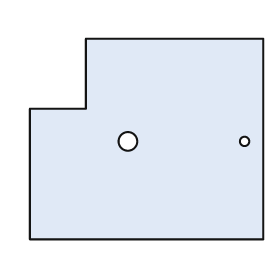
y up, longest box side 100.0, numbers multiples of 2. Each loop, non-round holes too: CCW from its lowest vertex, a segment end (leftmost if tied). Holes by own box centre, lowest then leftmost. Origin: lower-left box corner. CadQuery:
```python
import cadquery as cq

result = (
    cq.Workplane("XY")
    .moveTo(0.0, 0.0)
    .lineTo(100.0, 0.0)
    .lineTo(100.0, 86.0)
    .lineTo(24.0, 86.0)
    .lineTo(24.0, 56.0)
    .lineTo(0.0, 56.0)
    .close()
    .moveTo(42.0, 42.0)
    .circle(4.0)
    .moveTo(92.0, 42.0)
    .circle(2.0)
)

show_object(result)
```